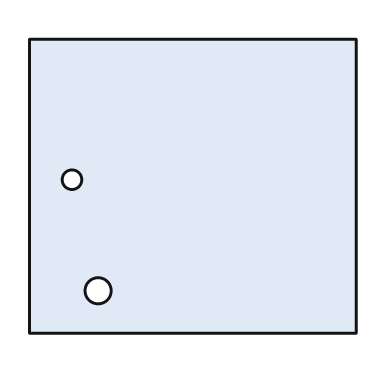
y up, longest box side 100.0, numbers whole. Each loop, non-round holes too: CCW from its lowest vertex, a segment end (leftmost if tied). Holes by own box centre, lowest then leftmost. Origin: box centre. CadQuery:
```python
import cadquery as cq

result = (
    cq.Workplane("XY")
    .moveTo(-50.0, -45.0)
    .lineTo(50.0, -45.0)
    .lineTo(50.0, 45.0)
    .lineTo(-50.0, 45.0)
    .close()
    .moveTo(-29.0, -32.0)
    .circle(4.0)
    .moveTo(-37.0, 2.0)
    .circle(3.0)
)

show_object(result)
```